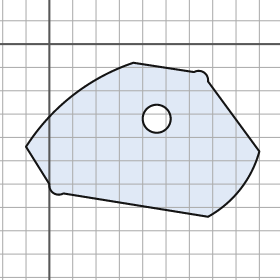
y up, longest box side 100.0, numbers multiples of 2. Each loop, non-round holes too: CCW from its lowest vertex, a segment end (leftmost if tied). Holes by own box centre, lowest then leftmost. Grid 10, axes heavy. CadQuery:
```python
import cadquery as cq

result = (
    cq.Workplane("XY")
    .moveTo(68.0, -74.0)
    .threePointArc((82.0, -62.0), (90.0, -46.0))
    .lineTo(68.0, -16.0)
    .threePointArc((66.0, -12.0), (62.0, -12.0))
    .lineTo(36.0, -8.0)
    .threePointArc((10.0, -22.0), (-10.0, -44.0))
    .lineTo(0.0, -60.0)
    .threePointArc((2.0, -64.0), (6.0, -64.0))
    .close()
    .moveTo(46.0, -32.0)
    .circle(6.0)
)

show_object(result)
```